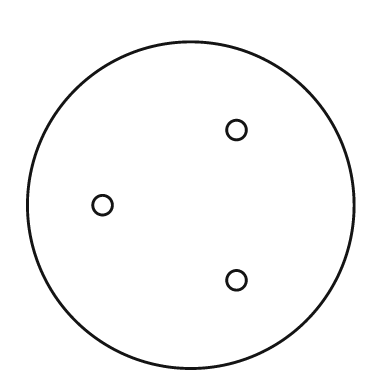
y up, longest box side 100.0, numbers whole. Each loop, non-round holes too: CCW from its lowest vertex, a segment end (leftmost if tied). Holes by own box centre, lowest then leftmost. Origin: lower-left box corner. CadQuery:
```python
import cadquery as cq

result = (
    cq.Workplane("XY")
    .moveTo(50.0, 50.0)
    .circle(50.0)
    .moveTo(64.0, 27.0)
    .circle(3.0)
    .moveTo(23.0, 50.0)
    .circle(3.0)
    .moveTo(64.0, 73.0)
    .circle(3.0)
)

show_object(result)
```